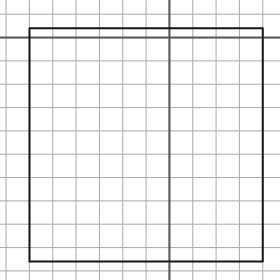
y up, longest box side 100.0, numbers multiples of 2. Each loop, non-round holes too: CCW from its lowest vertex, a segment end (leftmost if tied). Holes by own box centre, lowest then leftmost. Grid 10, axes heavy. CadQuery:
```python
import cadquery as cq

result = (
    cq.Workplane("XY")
    .moveTo(-60.0, -96.0)
    .lineTo(40.0, -96.0)
    .lineTo(40.0, 4.0)
    .lineTo(-60.0, 4.0)
    .close()
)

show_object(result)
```